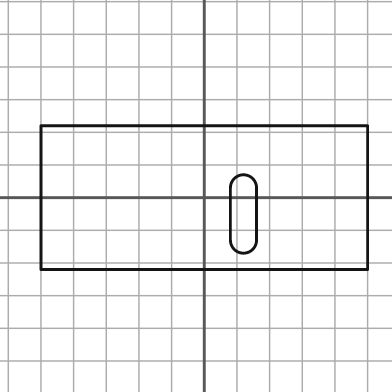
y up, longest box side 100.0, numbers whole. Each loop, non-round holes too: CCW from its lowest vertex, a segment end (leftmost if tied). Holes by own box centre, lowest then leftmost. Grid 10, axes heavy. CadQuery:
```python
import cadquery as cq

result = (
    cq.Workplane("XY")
    .moveTo(-50.0, -22.0)
    .lineTo(50.0, -22.0)
    .lineTo(50.0, 22.0)
    .lineTo(-50.0, 22.0)
    .close()
    .moveTo(8.0, -13.0)
    .threePointArc((12.0, -17.0), (16.0, -13.0))
    .lineTo(16.0, 3.0)
    .threePointArc((12.0, 7.0), (8.0, 3.0))
    .close()
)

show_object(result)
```